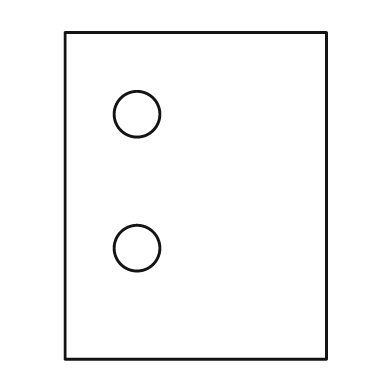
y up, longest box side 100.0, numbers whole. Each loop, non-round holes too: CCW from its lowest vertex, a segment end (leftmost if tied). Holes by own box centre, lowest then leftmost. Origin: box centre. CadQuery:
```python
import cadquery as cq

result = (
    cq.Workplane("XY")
    .moveTo(-40.0, -50.0)
    .lineTo(40.0, -50.0)
    .lineTo(40.0, 50.0)
    .lineTo(-40.0, 50.0)
    .close()
    .moveTo(-18.0, -16.0)
    .circle(7.0)
    .moveTo(-18.0, 25.0)
    .circle(7.0)
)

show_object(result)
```